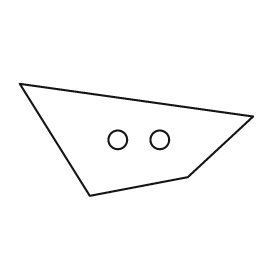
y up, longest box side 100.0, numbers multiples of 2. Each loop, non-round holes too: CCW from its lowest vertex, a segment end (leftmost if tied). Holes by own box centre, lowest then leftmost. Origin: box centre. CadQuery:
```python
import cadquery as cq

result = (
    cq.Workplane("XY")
    .moveTo(-20.0, -24.0)
    .lineTo(22.0, -16.0)
    .lineTo(50.0, 10.0)
    .lineTo(-50.0, 24.0)
    .close()
    .moveTo(-8.0, 0.0)
    .circle(4.0)
    .moveTo(10.0, 0.0)
    .circle(4.0)
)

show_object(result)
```